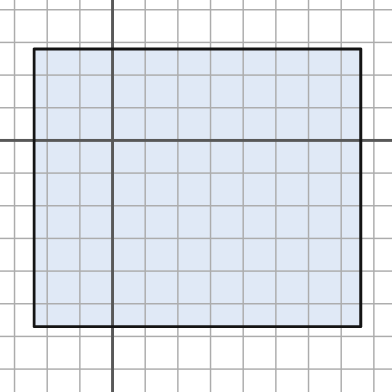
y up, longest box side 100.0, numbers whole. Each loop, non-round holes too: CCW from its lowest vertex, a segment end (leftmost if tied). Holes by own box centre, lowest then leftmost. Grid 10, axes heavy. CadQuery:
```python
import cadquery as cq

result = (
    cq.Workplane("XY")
    .moveTo(-24.0, -57.0)
    .lineTo(76.0, -57.0)
    .lineTo(76.0, 28.0)
    .lineTo(-24.0, 28.0)
    .close()
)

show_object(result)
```